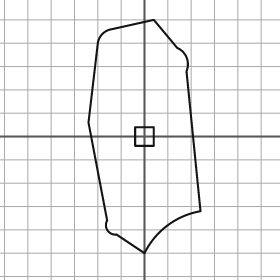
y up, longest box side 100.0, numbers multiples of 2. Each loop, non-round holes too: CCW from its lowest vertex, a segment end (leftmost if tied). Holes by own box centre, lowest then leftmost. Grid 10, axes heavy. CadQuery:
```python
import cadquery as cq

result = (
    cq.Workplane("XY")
    .moveTo(0.0, -50.0)
    .threePointArc((10.0, -38.0), (24.0, -32.0))
    .lineTo(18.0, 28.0)
    .threePointArc((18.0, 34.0), (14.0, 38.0))
    .lineTo(4.0, 50.0)
    .lineTo(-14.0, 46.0)
    .threePointArc((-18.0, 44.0), (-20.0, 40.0))
    .lineTo(-24.0, 6.0)
    .lineTo(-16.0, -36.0)
    .threePointArc((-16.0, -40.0), (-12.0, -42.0))
    .close()
    .moveTo(-4.0, -4.0)
    .lineTo(4.0, -4.0)
    .lineTo(4.0, 4.0)
    .lineTo(-4.0, 4.0)
    .close()
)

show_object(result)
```